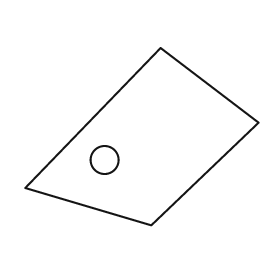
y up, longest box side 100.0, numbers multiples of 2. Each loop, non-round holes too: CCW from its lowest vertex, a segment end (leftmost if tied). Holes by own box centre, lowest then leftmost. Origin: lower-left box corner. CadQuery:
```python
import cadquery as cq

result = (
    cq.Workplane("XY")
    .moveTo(54.0, 0.0)
    .lineTo(100.0, 44.0)
    .lineTo(58.0, 76.0)
    .lineTo(0.0, 16.0)
    .close()
    .moveTo(34.0, 28.0)
    .circle(6.0)
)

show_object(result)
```